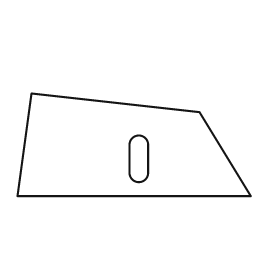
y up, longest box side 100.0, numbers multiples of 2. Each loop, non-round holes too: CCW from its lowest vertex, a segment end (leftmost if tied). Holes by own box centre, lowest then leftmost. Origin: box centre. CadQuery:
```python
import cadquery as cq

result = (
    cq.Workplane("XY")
    .moveTo(-50.0, -22.0)
    .lineTo(50.0, -22.0)
    .lineTo(28.0, 14.0)
    .lineTo(-44.0, 22.0)
    .close()
    .moveTo(-2.0, -12.0)
    .threePointArc((2.0, -16.0), (6.0, -12.0))
    .lineTo(6.0, 0.0)
    .threePointArc((2.0, 4.0), (-2.0, 0.0))
    .close()
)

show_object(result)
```